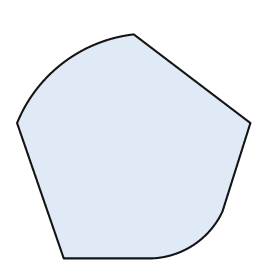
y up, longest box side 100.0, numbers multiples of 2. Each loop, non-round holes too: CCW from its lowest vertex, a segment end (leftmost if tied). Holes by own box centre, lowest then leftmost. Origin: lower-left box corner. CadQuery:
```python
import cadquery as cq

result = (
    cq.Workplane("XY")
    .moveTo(20.0, 0.0)
    .lineTo(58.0, 0.0)
    .threePointArc((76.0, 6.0), (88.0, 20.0))
    .lineTo(100.0, 58.0)
    .lineTo(50.0, 96.0)
    .threePointArc((20.0, 84.0), (0.0, 58.0))
    .close()
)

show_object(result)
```